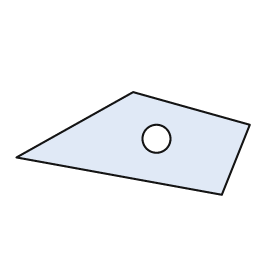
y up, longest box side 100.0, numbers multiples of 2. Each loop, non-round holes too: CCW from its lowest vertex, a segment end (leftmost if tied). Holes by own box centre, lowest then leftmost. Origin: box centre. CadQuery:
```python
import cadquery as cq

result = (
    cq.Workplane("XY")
    .moveTo(38.0, -22.0)
    .lineTo(50.0, 8.0)
    .lineTo(0.0, 22.0)
    .lineTo(-50.0, -6.0)
    .close()
    .moveTo(10.0, 2.0)
    .circle(6.0)
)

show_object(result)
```